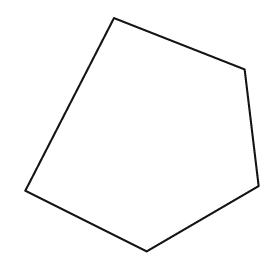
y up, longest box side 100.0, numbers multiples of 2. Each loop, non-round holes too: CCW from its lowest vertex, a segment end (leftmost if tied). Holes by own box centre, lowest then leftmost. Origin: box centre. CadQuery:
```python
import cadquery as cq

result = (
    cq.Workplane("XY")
    .moveTo(2.0, -50.0)
    .lineTo(50.0, -22.0)
    .lineTo(44.0, 28.0)
    .lineTo(-12.0, 50.0)
    .lineTo(-50.0, -24.0)
    .close()
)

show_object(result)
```